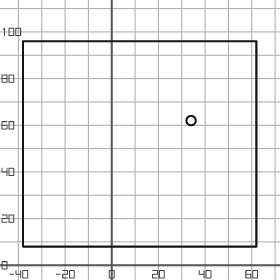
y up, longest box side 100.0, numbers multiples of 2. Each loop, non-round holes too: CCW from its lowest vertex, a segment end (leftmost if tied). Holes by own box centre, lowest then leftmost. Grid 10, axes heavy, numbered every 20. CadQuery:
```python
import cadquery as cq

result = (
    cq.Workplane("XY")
    .moveTo(-38.0, 8.0)
    .lineTo(62.0, 8.0)
    .lineTo(62.0, 96.0)
    .lineTo(-38.0, 96.0)
    .close()
    .moveTo(34.0, 62.0)
    .circle(2.0)
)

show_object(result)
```